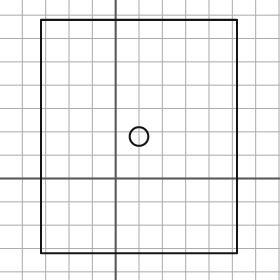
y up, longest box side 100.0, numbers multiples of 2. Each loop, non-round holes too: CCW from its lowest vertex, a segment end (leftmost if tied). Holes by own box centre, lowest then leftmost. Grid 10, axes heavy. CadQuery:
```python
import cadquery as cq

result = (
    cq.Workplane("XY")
    .moveTo(-32.0, -32.0)
    .lineTo(52.0, -32.0)
    .lineTo(52.0, 68.0)
    .lineTo(-32.0, 68.0)
    .close()
    .moveTo(10.0, 18.0)
    .circle(4.0)
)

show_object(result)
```